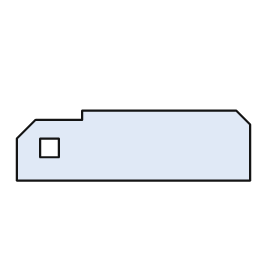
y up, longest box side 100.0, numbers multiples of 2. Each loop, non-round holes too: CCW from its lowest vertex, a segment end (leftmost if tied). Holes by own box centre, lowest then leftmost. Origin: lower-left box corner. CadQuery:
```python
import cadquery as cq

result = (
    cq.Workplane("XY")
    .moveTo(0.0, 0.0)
    .lineTo(100.0, 0.0)
    .lineTo(100.0, 24.0)
    .lineTo(94.0, 30.0)
    .lineTo(28.0, 30.0)
    .lineTo(28.0, 26.0)
    .lineTo(8.0, 26.0)
    .lineTo(0.0, 18.0)
    .close()
    .moveTo(10.0, 10.0)
    .lineTo(18.0, 10.0)
    .lineTo(18.0, 18.0)
    .lineTo(10.0, 18.0)
    .close()
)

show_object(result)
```